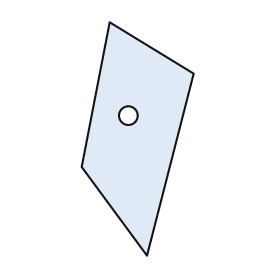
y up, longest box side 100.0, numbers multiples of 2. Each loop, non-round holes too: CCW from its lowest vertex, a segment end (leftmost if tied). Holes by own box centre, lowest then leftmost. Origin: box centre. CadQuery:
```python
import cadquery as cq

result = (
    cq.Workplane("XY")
    .moveTo(4.0, -50.0)
    .lineTo(24.0, 28.0)
    .lineTo(-12.0, 50.0)
    .lineTo(-24.0, -12.0)
    .close()
    .moveTo(-4.0, 10.0)
    .circle(4.0)
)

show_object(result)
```